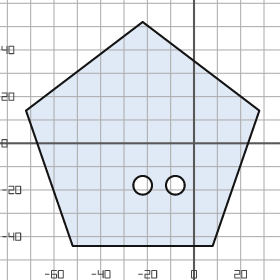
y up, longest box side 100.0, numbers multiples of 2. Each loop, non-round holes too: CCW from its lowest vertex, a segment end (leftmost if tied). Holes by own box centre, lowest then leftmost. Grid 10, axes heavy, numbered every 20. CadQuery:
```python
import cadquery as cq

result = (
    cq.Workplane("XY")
    .moveTo(-52.0, -44.0)
    .lineTo(8.0, -44.0)
    .lineTo(28.0, 14.0)
    .lineTo(-22.0, 52.0)
    .lineTo(-72.0, 14.0)
    .close()
    .moveTo(-22.0, -18.0)
    .circle(4.0)
    .moveTo(-8.0, -18.0)
    .circle(4.0)
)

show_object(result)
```